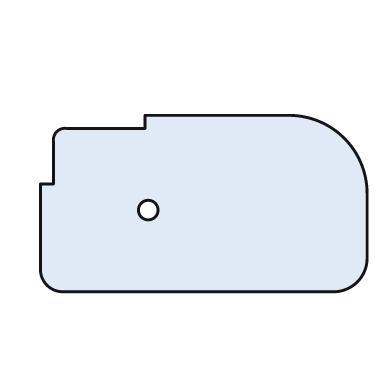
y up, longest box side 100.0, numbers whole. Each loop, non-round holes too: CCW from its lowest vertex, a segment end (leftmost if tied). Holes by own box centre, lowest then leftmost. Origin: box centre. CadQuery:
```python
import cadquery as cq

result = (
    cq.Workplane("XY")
    .moveTo(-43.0, -27.0)
    .lineTo(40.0, -27.0)
    .threePointArc((47.0, -24.0), (50.0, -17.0))
    .lineTo(50.0, 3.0)
    .threePointArc((43.0, 20.0), (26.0, 27.0))
    .lineTo(-18.0, 27.0)
    .lineTo(-18.0, 23.0)
    .lineTo(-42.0, 23.0)
    .threePointArc((-45.0, 22.0), (-46.0, 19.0))
    .lineTo(-46.0, 6.0)
    .lineTo(-50.0, 6.0)
    .lineTo(-50.0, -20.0)
    .threePointArc((-48.0, -25.0), (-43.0, -27.0))
    .close()
    .moveTo(-17.0, -2.0)
    .circle(3.0)
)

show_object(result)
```